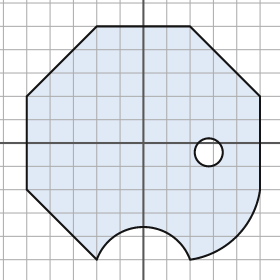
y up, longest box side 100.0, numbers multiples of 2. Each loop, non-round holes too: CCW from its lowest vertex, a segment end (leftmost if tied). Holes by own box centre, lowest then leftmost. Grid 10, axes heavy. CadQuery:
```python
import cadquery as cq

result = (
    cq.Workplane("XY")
    .moveTo(-20.0, -50.0)
    .threePointArc((0.0, -36.0), (20.0, -50.0))
    .threePointArc((40.0, -40.0), (50.0, -20.0))
    .lineTo(50.0, 20.0)
    .lineTo(20.0, 50.0)
    .lineTo(-20.0, 50.0)
    .lineTo(-50.0, 20.0)
    .lineTo(-50.0, -20.0)
    .close()
    .moveTo(28.0, -4.0)
    .circle(6.0)
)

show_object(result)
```